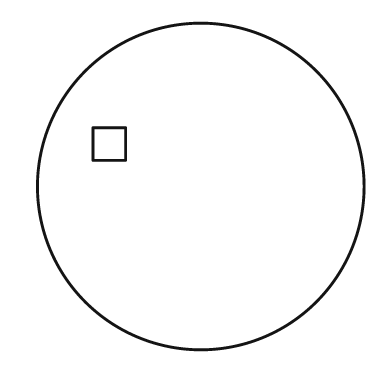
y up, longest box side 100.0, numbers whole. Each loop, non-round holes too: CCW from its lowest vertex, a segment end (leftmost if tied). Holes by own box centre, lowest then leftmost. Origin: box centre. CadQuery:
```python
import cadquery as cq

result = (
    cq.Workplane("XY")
    .moveTo(0.0, 0.0)
    .circle(50.0)
    .moveTo(-33.0, 8.0)
    .lineTo(-23.0, 8.0)
    .lineTo(-23.0, 18.0)
    .lineTo(-33.0, 18.0)
    .close()
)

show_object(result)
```